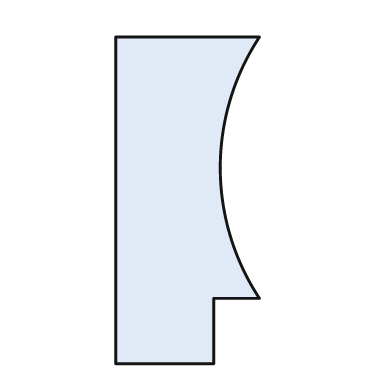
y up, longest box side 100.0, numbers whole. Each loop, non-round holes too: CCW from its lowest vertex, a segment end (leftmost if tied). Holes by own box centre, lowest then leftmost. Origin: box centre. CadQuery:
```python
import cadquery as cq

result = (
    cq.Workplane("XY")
    .moveTo(-22.0, -50.0)
    .lineTo(8.0, -50.0)
    .lineTo(8.0, -30.0)
    .lineTo(22.0, -30.0)
    .threePointArc((10.0, 10.0), (22.0, 50.0))
    .lineTo(-22.0, 50.0)
    .close()
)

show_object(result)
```